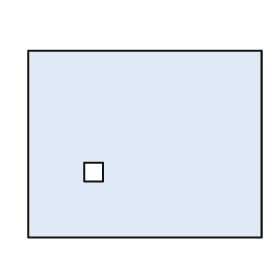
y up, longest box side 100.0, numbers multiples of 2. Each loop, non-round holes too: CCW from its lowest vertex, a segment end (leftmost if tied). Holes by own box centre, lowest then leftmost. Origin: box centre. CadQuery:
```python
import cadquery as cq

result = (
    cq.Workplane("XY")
    .moveTo(-50.0, -40.0)
    .lineTo(50.0, -40.0)
    .lineTo(50.0, 40.0)
    .lineTo(-50.0, 40.0)
    .close()
    .moveTo(-26.0, -16.0)
    .lineTo(-18.0, -16.0)
    .lineTo(-18.0, -8.0)
    .lineTo(-26.0, -8.0)
    .close()
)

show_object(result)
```